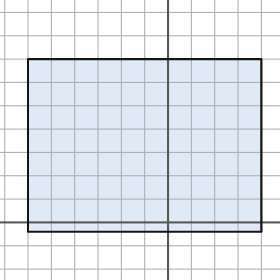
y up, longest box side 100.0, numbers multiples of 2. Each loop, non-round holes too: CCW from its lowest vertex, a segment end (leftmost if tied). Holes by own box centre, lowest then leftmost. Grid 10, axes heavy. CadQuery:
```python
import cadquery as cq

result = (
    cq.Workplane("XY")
    .moveTo(-60.0, -4.0)
    .lineTo(40.0, -4.0)
    .lineTo(40.0, 70.0)
    .lineTo(-60.0, 70.0)
    .close()
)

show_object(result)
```